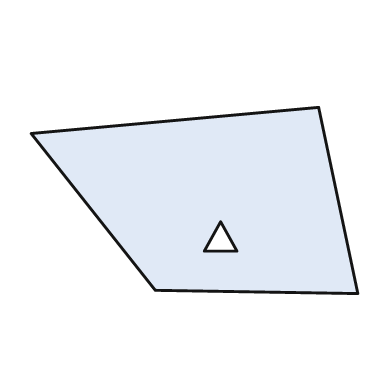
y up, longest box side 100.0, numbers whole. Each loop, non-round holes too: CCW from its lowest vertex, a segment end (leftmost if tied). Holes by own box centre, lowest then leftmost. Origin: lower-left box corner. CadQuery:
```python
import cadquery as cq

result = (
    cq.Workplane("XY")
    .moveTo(100.0, 0.0)
    .lineTo(88.0, 57.0)
    .lineTo(0.0, 49.0)
    .lineTo(38.0, 1.0)
    .close()
    .moveTo(53.0, 13.0)
    .lineTo(63.0, 13.0)
    .lineTo(58.0, 22.0)
    .close()
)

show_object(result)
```